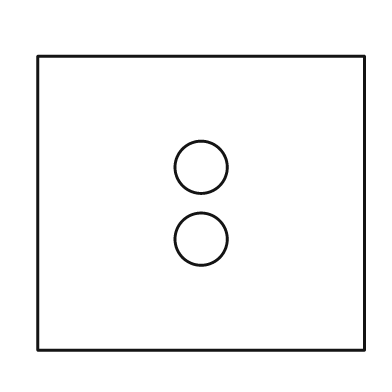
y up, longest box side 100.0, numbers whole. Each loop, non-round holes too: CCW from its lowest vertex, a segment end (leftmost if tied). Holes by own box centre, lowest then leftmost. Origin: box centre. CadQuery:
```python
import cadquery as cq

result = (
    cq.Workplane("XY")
    .moveTo(-50.0, -45.0)
    .lineTo(50.0, -45.0)
    .lineTo(50.0, 45.0)
    .lineTo(-50.0, 45.0)
    .close()
    .moveTo(0.0, -11.0)
    .circle(8.0)
    .moveTo(0.0, 11.0)
    .circle(8.0)
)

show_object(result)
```